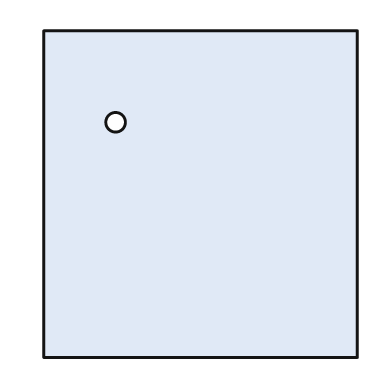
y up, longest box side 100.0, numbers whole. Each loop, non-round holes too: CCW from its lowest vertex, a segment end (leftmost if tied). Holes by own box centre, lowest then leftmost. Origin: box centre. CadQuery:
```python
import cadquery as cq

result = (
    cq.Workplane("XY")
    .moveTo(-48.0, -50.0)
    .lineTo(48.0, -50.0)
    .lineTo(48.0, 50.0)
    .lineTo(-48.0, 50.0)
    .close()
    .moveTo(-26.0, 22.0)
    .circle(3.0)
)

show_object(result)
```